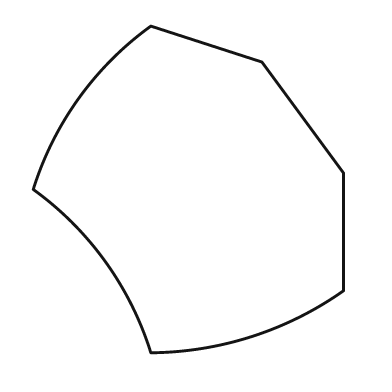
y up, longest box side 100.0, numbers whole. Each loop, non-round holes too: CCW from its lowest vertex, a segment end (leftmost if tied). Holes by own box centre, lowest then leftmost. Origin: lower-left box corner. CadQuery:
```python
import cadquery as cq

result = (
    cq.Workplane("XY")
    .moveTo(36.0, 0.0)
    .threePointArc((67.0, 5.0), (95.0, 19.0))
    .lineTo(95.0, 55.0)
    .lineTo(70.0, 89.0)
    .lineTo(36.0, 100.0)
    .threePointArc((14.0, 78.0), (0.0, 50.0))
    .threePointArc((22.0, 28.0), (36.0, 0.0))
    .close()
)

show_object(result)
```